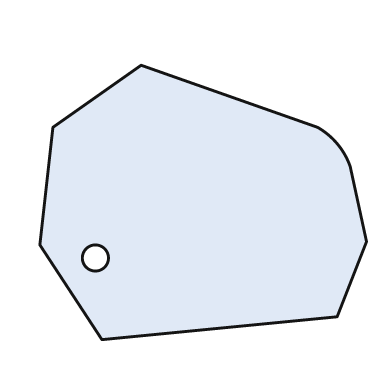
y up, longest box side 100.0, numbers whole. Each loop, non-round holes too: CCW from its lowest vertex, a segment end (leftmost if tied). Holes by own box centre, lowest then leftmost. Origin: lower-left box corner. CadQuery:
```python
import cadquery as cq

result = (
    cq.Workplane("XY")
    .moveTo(19.0, 0.0)
    .lineTo(91.0, 7.0)
    .lineTo(100.0, 30.0)
    .lineTo(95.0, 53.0)
    .threePointArc((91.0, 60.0), (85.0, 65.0))
    .lineTo(31.0, 84.0)
    .lineTo(4.0, 65.0)
    .lineTo(0.0, 29.0)
    .close()
    .moveTo(17.0, 25.0)
    .circle(4.0)
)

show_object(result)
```